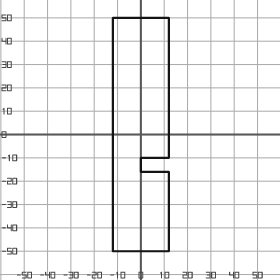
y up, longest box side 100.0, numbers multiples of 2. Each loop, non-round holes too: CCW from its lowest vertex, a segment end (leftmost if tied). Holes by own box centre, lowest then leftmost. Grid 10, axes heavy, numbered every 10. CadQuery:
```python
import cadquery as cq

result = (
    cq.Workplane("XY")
    .moveTo(-12.0, -50.0)
    .lineTo(12.0, -50.0)
    .lineTo(12.0, -16.0)
    .lineTo(0.0, -16.0)
    .lineTo(0.0, -10.0)
    .lineTo(12.0, -10.0)
    .lineTo(12.0, 50.0)
    .lineTo(-12.0, 50.0)
    .close()
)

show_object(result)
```